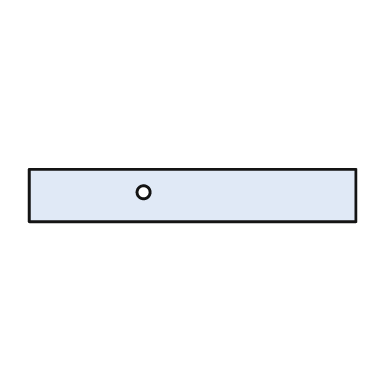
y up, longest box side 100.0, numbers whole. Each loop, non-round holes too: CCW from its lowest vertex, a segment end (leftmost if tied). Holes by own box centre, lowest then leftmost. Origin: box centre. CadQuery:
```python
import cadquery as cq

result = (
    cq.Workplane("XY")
    .moveTo(-50.0, -8.0)
    .lineTo(50.0, -8.0)
    .lineTo(50.0, 8.0)
    .lineTo(-50.0, 8.0)
    .close()
    .moveTo(-15.0, 1.0)
    .circle(2.0)
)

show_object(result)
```